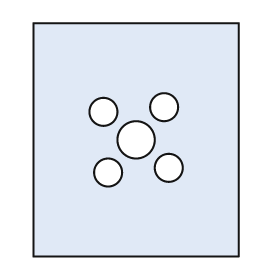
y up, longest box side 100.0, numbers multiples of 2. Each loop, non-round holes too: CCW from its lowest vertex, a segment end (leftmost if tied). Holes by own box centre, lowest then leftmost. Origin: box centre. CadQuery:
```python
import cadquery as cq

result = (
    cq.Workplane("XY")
    .moveTo(-44.0, -50.0)
    .lineTo(44.0, -50.0)
    .lineTo(44.0, 50.0)
    .lineTo(-44.0, 50.0)
    .close()
    .moveTo(-12.0, -14.0)
    .circle(6.0)
    .moveTo(14.0, -12.0)
    .circle(6.0)
    .moveTo(0.0, 0.0)
    .circle(8.0)
    .moveTo(-14.0, 12.0)
    .circle(6.0)
    .moveTo(12.0, 14.0)
    .circle(6.0)
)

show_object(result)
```